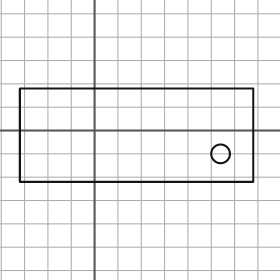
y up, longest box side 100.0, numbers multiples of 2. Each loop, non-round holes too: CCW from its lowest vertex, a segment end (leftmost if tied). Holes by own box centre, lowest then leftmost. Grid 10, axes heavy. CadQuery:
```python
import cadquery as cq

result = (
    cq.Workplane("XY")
    .moveTo(-32.0, -22.0)
    .lineTo(68.0, -22.0)
    .lineTo(68.0, 18.0)
    .lineTo(-32.0, 18.0)
    .close()
    .moveTo(54.0, -10.0)
    .circle(4.0)
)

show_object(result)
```